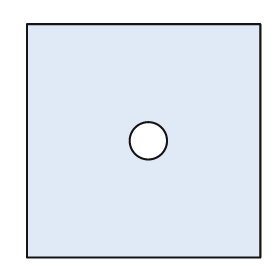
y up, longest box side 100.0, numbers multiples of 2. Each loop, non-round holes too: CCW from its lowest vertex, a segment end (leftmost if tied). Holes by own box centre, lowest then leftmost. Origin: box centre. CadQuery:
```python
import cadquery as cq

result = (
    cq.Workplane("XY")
    .moveTo(-50.0, -50.0)
    .lineTo(50.0, -50.0)
    .lineTo(50.0, 50.0)
    .lineTo(-50.0, 50.0)
    .close()
    .moveTo(2.0, 0.0)
    .circle(8.0)
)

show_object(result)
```